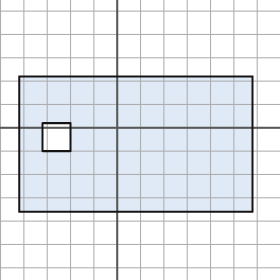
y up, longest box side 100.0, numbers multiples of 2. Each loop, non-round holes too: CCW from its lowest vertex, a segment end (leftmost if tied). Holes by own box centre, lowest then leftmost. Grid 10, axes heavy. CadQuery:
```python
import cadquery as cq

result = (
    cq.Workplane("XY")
    .moveTo(-42.0, -36.0)
    .lineTo(58.0, -36.0)
    .lineTo(58.0, 22.0)
    .lineTo(-42.0, 22.0)
    .close()
    .moveTo(-32.0, -10.0)
    .lineTo(-20.0, -10.0)
    .lineTo(-20.0, 2.0)
    .lineTo(-32.0, 2.0)
    .close()
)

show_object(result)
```